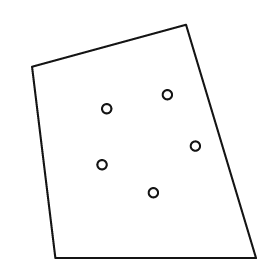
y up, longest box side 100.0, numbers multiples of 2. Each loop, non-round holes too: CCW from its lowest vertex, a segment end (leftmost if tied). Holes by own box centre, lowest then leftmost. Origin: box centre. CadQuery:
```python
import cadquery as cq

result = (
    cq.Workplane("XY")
    .moveTo(-38.0, -50.0)
    .lineTo(48.0, -50.0)
    .lineTo(18.0, 50.0)
    .lineTo(-48.0, 32.0)
    .close()
    .moveTo(4.0, -22.0)
    .circle(2.0)
    .moveTo(-18.0, -10.0)
    .circle(2.0)
    .moveTo(22.0, -2.0)
    .circle(2.0)
    .moveTo(-16.0, 14.0)
    .circle(2.0)
    .moveTo(10.0, 20.0)
    .circle(2.0)
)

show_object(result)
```